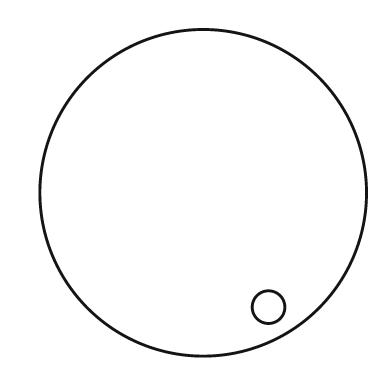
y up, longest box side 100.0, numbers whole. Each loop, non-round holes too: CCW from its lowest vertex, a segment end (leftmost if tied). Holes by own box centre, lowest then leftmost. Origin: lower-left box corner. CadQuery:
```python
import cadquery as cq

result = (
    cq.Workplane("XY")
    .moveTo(50.0, 50.0)
    .circle(50.0)
    .moveTo(70.0, 15.0)
    .circle(5.0)
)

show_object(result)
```